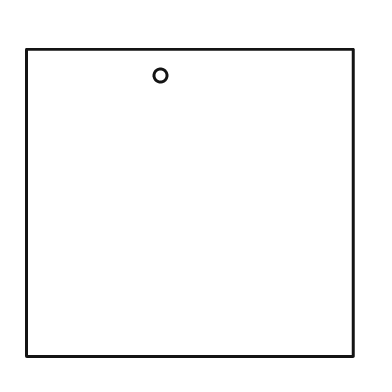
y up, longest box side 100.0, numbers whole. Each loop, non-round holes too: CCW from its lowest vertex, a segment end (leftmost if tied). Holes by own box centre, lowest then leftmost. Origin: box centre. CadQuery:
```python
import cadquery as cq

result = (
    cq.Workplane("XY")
    .moveTo(-50.0, -47.0)
    .lineTo(50.0, -47.0)
    .lineTo(50.0, 47.0)
    .lineTo(-50.0, 47.0)
    .close()
    .moveTo(-9.0, 39.0)
    .circle(2.0)
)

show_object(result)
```